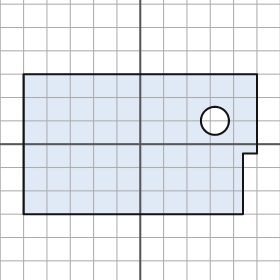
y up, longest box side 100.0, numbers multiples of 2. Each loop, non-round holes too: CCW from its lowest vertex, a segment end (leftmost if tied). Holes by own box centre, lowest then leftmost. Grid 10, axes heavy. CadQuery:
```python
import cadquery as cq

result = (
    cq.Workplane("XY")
    .moveTo(-50.0, -30.0)
    .lineTo(44.0, -30.0)
    .lineTo(44.0, -4.0)
    .lineTo(50.0, -4.0)
    .lineTo(50.0, 30.0)
    .lineTo(-50.0, 30.0)
    .close()
    .moveTo(32.0, 10.0)
    .circle(6.0)
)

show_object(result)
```